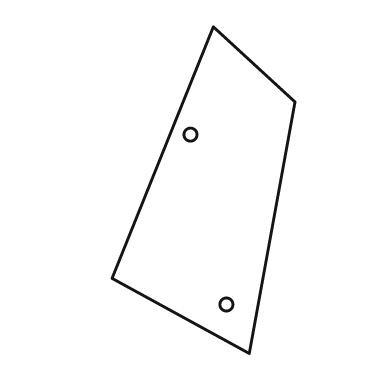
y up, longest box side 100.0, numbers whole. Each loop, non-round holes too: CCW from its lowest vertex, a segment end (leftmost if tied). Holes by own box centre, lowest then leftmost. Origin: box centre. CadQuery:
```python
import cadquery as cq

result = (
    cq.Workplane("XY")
    .moveTo(14.0, -50.0)
    .lineTo(28.0, 27.0)
    .lineTo(3.0, 50.0)
    .lineTo(-28.0, -27.0)
    .close()
    .moveTo(7.0, -35.0)
    .circle(2.0)
    .moveTo(-4.0, 17.0)
    .circle(2.0)
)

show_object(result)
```